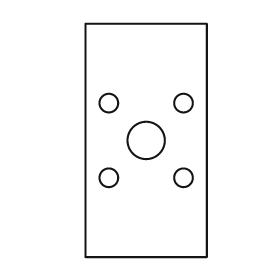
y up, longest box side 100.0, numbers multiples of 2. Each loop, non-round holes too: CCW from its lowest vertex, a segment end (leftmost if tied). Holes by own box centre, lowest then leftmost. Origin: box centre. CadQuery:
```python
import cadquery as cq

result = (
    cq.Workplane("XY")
    .moveTo(-26.0, -50.0)
    .lineTo(26.0, -50.0)
    .lineTo(26.0, 50.0)
    .lineTo(-26.0, 50.0)
    .close()
    .moveTo(-16.0, -16.0)
    .circle(4.0)
    .moveTo(16.0, -16.0)
    .circle(4.0)
    .moveTo(0.0, 0.0)
    .circle(8.0)
    .moveTo(-16.0, 16.0)
    .circle(4.0)
    .moveTo(16.0, 16.0)
    .circle(4.0)
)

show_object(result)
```